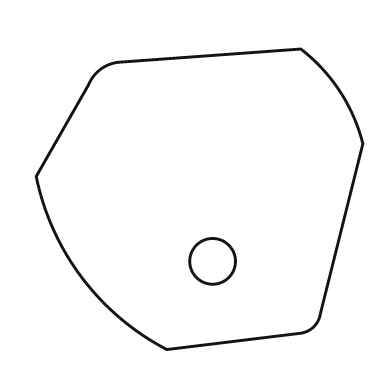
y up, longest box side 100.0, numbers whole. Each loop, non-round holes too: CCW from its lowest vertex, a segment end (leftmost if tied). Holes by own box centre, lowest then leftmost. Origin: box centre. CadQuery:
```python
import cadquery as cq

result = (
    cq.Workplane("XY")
    .moveTo(-10.0, -46.0)
    .lineTo(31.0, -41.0)
    .threePointArc((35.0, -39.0), (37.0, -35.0))
    .lineTo(50.0, 17.0)
    .threePointArc((43.0, 33.0), (31.0, 46.0))
    .lineTo(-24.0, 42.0)
    .threePointArc((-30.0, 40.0), (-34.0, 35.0))
    .lineTo(-50.0, 7.0)
    .threePointArc((-36.0, -24.0), (-10.0, -46.0))
    .close()
    .moveTo(4.0, -19.0)
    .circle(7.0)
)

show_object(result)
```